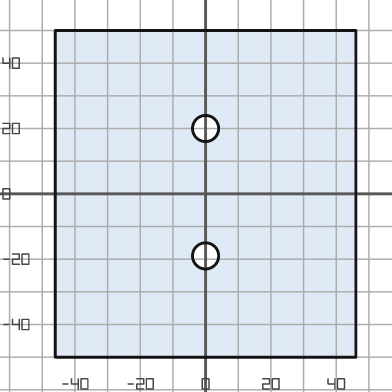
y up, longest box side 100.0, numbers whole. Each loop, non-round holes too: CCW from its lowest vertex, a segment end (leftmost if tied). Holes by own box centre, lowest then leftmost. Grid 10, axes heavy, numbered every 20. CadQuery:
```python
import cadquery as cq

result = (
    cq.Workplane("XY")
    .moveTo(-46.0, -50.0)
    .lineTo(46.0, -50.0)
    .lineTo(46.0, 50.0)
    .lineTo(-46.0, 50.0)
    .close()
    .moveTo(0.0, -19.0)
    .circle(4.0)
    .moveTo(0.0, 20.0)
    .circle(4.0)
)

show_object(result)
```